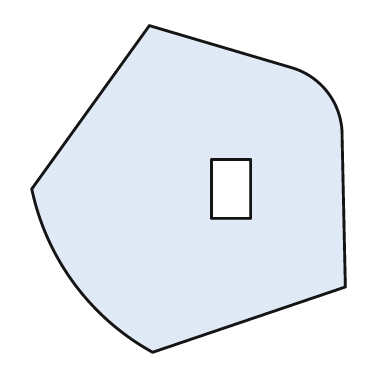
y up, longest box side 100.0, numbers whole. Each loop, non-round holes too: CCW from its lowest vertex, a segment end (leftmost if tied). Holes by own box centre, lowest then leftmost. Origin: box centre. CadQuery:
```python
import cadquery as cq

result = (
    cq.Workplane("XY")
    .moveTo(-11.0, -50.0)
    .lineTo(48.0, -30.0)
    .lineTo(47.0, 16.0)
    .threePointArc((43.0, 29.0), (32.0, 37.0))
    .lineTo(-12.0, 50.0)
    .lineTo(-48.0, 0.0)
    .threePointArc((-35.0, -29.0), (-11.0, -50.0))
    .close()
    .moveTo(7.0, -9.0)
    .lineTo(19.0, -9.0)
    .lineTo(19.0, 9.0)
    .lineTo(7.0, 9.0)
    .close()
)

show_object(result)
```